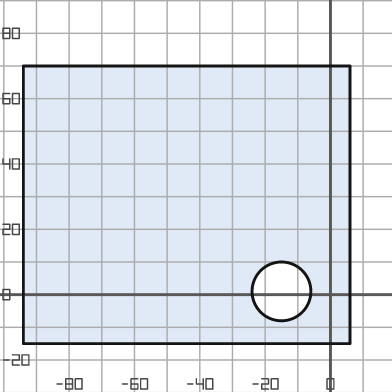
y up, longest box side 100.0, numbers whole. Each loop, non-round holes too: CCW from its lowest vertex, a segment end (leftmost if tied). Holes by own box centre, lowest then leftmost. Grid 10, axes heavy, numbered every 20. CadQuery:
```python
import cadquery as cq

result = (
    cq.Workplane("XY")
    .moveTo(-94.0, -15.0)
    .lineTo(6.0, -15.0)
    .lineTo(6.0, 70.0)
    .lineTo(-94.0, 70.0)
    .close()
    .moveTo(-15.0, 1.0)
    .circle(9.0)
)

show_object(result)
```